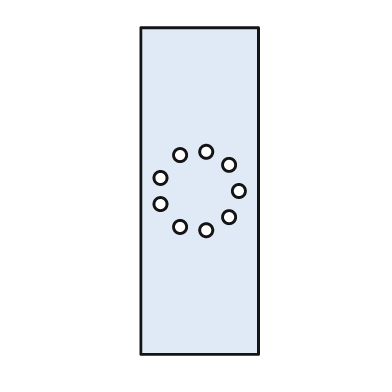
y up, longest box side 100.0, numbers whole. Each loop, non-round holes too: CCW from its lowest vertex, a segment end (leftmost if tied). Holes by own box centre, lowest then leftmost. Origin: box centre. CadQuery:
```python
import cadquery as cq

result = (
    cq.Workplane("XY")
    .moveTo(-18.0, -50.0)
    .lineTo(18.0, -50.0)
    .lineTo(18.0, 50.0)
    .lineTo(-18.0, 50.0)
    .close()
    .moveTo(2.0, -12.0)
    .circle(2.0)
    .moveTo(-6.0, -11.0)
    .circle(2.0)
    .moveTo(9.0, -8.0)
    .circle(2.0)
    .moveTo(-12.0, -4.0)
    .circle(2.0)
    .moveTo(12.0, 0.0)
    .circle(2.0)
    .moveTo(-12.0, 4.0)
    .circle(2.0)
    .moveTo(9.0, 8.0)
    .circle(2.0)
    .moveTo(-6.0, 11.0)
    .circle(2.0)
    .moveTo(2.0, 12.0)
    .circle(2.0)
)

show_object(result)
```